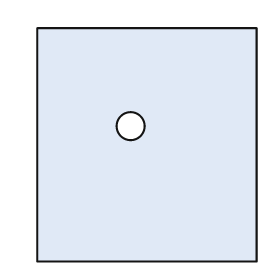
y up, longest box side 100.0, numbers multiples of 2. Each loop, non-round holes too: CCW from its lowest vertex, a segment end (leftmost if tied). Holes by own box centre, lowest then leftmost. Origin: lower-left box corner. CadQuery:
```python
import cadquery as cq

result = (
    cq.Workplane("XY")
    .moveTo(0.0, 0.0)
    .lineTo(94.0, 0.0)
    .lineTo(94.0, 100.0)
    .lineTo(0.0, 100.0)
    .close()
    .moveTo(40.0, 58.0)
    .circle(6.0)
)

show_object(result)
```